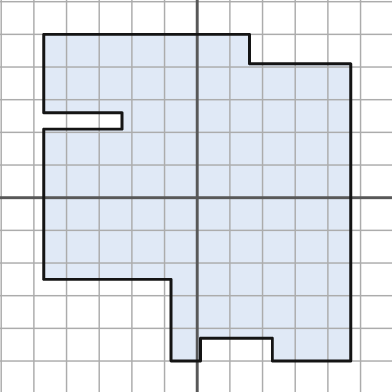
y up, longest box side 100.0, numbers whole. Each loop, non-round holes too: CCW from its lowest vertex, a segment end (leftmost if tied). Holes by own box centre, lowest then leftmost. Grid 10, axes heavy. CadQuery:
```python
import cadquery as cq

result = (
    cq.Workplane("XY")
    .moveTo(-8.0, -50.0)
    .lineTo(1.0, -50.0)
    .lineTo(1.0, -43.0)
    .lineTo(23.0, -43.0)
    .lineTo(23.0, -50.0)
    .lineTo(47.0, -50.0)
    .lineTo(47.0, 41.0)
    .lineTo(16.0, 41.0)
    .lineTo(16.0, 50.0)
    .lineTo(-47.0, 50.0)
    .lineTo(-47.0, 26.0)
    .lineTo(-23.0, 26.0)
    .lineTo(-23.0, 21.0)
    .lineTo(-47.0, 21.0)
    .lineTo(-47.0, -25.0)
    .lineTo(-8.0, -25.0)
    .close()
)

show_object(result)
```